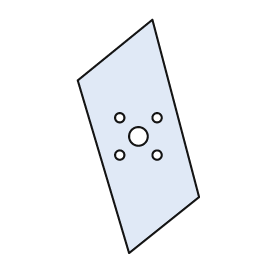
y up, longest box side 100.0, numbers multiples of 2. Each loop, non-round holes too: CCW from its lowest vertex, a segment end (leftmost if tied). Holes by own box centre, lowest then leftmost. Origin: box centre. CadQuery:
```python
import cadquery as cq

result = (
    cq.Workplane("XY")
    .moveTo(-4.0, -50.0)
    .lineTo(26.0, -26.0)
    .lineTo(6.0, 50.0)
    .lineTo(-26.0, 24.0)
    .close()
    .moveTo(-8.0, -8.0)
    .circle(2.0)
    .moveTo(8.0, -8.0)
    .circle(2.0)
    .moveTo(0.0, 0.0)
    .circle(4.0)
    .moveTo(-8.0, 8.0)
    .circle(2.0)
    .moveTo(8.0, 8.0)
    .circle(2.0)
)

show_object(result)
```